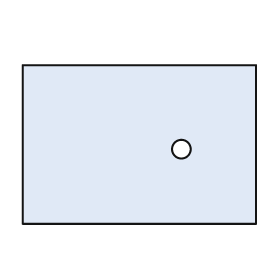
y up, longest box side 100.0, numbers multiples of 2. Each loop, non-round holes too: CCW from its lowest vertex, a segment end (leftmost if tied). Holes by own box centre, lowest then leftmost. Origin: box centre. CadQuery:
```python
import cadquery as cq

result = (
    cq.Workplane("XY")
    .moveTo(-50.0, -34.0)
    .lineTo(50.0, -34.0)
    .lineTo(50.0, 34.0)
    .lineTo(-50.0, 34.0)
    .close()
    .moveTo(18.0, -2.0)
    .circle(4.0)
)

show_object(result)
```